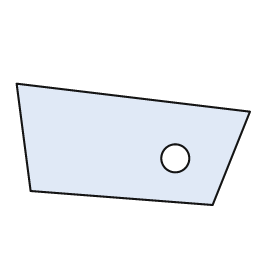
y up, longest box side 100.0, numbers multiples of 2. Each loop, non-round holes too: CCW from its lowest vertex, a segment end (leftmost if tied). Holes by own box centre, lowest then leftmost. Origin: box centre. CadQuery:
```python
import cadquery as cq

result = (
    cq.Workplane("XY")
    .moveTo(34.0, -26.0)
    .lineTo(50.0, 14.0)
    .lineTo(-50.0, 26.0)
    .lineTo(-44.0, -20.0)
    .close()
    .moveTo(18.0, -6.0)
    .circle(6.0)
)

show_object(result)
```